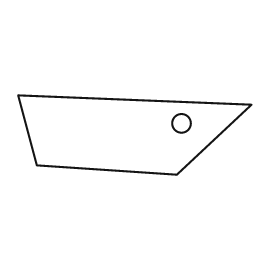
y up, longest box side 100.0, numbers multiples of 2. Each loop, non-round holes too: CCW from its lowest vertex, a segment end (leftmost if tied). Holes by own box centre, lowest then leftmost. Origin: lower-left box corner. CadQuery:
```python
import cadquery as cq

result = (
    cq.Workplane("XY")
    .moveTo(68.0, 0.0)
    .lineTo(100.0, 30.0)
    .lineTo(0.0, 34.0)
    .lineTo(8.0, 4.0)
    .close()
    .moveTo(70.0, 22.0)
    .circle(4.0)
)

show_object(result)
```